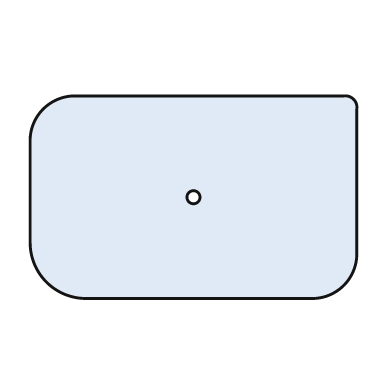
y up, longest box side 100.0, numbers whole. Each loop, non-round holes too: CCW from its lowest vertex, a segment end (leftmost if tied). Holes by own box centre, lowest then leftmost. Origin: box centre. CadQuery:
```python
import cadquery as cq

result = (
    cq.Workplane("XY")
    .moveTo(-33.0, -31.0)
    .lineTo(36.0, -31.0)
    .threePointArc((46.0, -27.0), (50.0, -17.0))
    .lineTo(50.0, 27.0)
    .threePointArc((49.0, 30.0), (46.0, 31.0))
    .lineTo(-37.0, 31.0)
    .threePointArc((-46.0, 27.0), (-50.0, 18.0))
    .lineTo(-50.0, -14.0)
    .threePointArc((-45.0, -26.0), (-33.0, -31.0))
    .close()
    .moveTo(0.0, 0.0)
    .circle(2.0)
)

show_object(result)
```